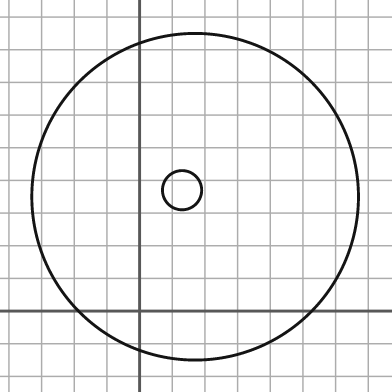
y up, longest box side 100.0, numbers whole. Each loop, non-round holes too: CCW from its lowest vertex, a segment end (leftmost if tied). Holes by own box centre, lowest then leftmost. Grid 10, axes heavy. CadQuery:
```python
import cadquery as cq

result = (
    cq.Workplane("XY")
    .moveTo(17.0, 35.0)
    .circle(50.0)
    .moveTo(13.0, 37.0)
    .circle(6.0)
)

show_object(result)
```